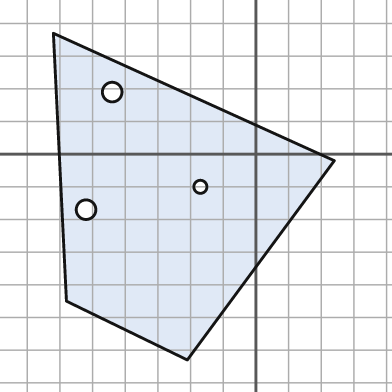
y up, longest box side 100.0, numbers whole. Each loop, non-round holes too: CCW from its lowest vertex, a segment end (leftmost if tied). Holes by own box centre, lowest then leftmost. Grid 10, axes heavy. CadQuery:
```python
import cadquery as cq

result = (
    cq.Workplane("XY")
    .moveTo(-21.0, -63.0)
    .lineTo(24.0, -2.0)
    .lineTo(-62.0, 37.0)
    .lineTo(-58.0, -45.0)
    .close()
    .moveTo(-52.0, -17.0)
    .circle(3.0)
    .moveTo(-17.0, -10.0)
    .circle(2.0)
    .moveTo(-44.0, 19.0)
    .circle(3.0)
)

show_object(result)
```